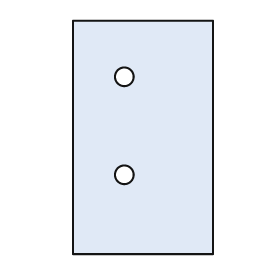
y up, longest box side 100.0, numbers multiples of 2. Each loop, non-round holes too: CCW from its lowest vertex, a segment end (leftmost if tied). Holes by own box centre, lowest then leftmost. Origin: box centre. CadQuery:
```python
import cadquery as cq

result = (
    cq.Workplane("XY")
    .moveTo(-30.0, -50.0)
    .lineTo(30.0, -50.0)
    .lineTo(30.0, 50.0)
    .lineTo(-30.0, 50.0)
    .close()
    .moveTo(-8.0, -16.0)
    .circle(4.0)
    .moveTo(-8.0, 26.0)
    .circle(4.0)
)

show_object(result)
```